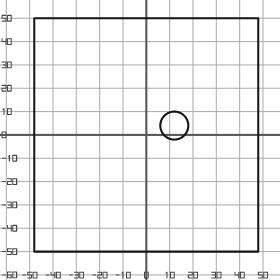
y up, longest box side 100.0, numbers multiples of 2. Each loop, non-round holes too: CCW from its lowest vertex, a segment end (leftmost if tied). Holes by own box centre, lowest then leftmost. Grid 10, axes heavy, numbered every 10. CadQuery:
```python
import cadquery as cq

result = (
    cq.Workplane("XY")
    .moveTo(-48.0, -50.0)
    .lineTo(48.0, -50.0)
    .lineTo(48.0, 50.0)
    .lineTo(-48.0, 50.0)
    .close()
    .moveTo(12.0, 4.0)
    .circle(6.0)
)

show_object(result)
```